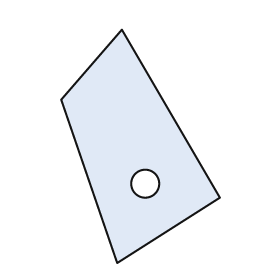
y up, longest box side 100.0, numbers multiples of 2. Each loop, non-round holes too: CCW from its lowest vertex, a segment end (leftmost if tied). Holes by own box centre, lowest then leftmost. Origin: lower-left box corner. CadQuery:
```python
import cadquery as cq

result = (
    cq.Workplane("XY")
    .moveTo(24.0, 0.0)
    .lineTo(68.0, 28.0)
    .lineTo(26.0, 100.0)
    .lineTo(0.0, 70.0)
    .close()
    .moveTo(36.0, 34.0)
    .circle(6.0)
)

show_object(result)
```